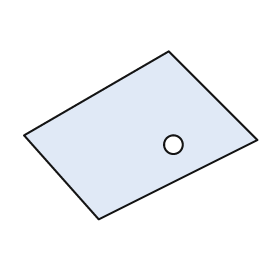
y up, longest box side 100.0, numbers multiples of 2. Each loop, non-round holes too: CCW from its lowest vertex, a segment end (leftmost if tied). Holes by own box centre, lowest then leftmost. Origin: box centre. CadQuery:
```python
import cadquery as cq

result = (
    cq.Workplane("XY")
    .moveTo(-18.0, -36.0)
    .lineTo(50.0, -2.0)
    .lineTo(12.0, 36.0)
    .lineTo(-50.0, 0.0)
    .close()
    .moveTo(14.0, -4.0)
    .circle(4.0)
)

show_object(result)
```